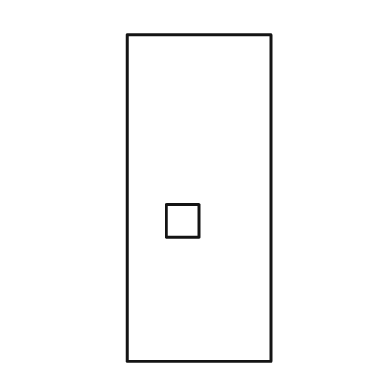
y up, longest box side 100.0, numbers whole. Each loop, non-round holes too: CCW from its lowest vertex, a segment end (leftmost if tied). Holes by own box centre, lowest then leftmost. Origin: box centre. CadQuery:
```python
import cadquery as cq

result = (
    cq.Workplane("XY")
    .moveTo(-22.0, -50.0)
    .lineTo(22.0, -50.0)
    .lineTo(22.0, 50.0)
    .lineTo(-22.0, 50.0)
    .close()
    .moveTo(-10.0, -12.0)
    .lineTo(0.0, -12.0)
    .lineTo(0.0, -2.0)
    .lineTo(-10.0, -2.0)
    .close()
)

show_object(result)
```